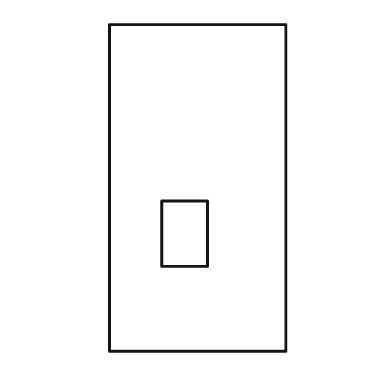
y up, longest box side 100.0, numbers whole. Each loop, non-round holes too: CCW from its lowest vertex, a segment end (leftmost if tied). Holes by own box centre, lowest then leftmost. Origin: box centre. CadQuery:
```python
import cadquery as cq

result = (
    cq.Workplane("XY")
    .moveTo(-27.0, -50.0)
    .lineTo(27.0, -50.0)
    .lineTo(27.0, 50.0)
    .lineTo(-27.0, 50.0)
    .close()
    .moveTo(-11.0, -24.0)
    .lineTo(3.0, -24.0)
    .lineTo(3.0, -4.0)
    .lineTo(-11.0, -4.0)
    .close()
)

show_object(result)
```